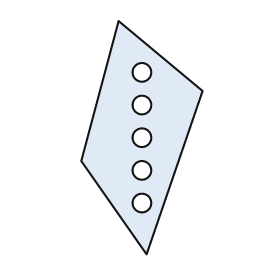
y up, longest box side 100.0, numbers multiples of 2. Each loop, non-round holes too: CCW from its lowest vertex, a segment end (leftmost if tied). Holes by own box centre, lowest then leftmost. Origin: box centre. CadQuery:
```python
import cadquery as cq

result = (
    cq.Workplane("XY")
    .moveTo(2.0, -50.0)
    .lineTo(26.0, 20.0)
    .lineTo(-10.0, 50.0)
    .lineTo(-26.0, -10.0)
    .close()
    .moveTo(0.0, -28.0)
    .circle(4.0)
    .moveTo(0.0, -14.0)
    .circle(4.0)
    .moveTo(0.0, 0.0)
    .circle(4.0)
    .moveTo(0.0, 14.0)
    .circle(4.0)
    .moveTo(0.0, 28.0)
    .circle(4.0)
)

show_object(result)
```